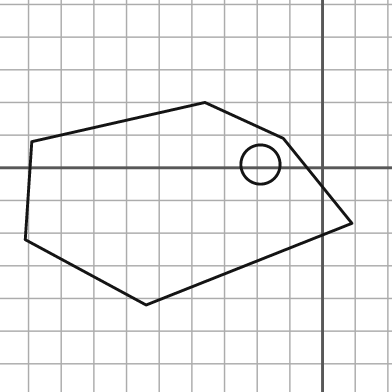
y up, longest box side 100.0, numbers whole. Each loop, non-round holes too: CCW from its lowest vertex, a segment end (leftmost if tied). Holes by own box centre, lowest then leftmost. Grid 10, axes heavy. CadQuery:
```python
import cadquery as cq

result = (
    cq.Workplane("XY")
    .moveTo(-54.0, -42.0)
    .lineTo(9.0, -17.0)
    .lineTo(-12.0, 9.0)
    .lineTo(-36.0, 20.0)
    .lineTo(-89.0, 8.0)
    .lineTo(-91.0, -22.0)
    .close()
    .moveTo(-19.0, 1.0)
    .circle(6.0)
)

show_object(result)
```